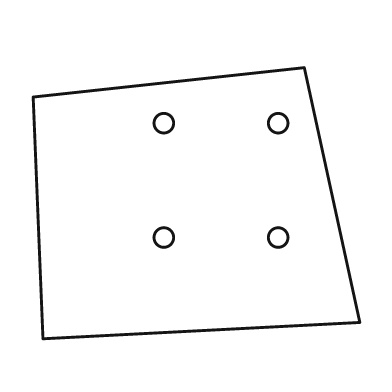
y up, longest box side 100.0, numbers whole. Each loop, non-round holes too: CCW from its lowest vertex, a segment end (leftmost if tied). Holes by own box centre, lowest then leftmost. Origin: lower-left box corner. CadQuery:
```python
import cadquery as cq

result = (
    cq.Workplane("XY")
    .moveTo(3.0, 0.0)
    .lineTo(100.0, 5.0)
    .lineTo(83.0, 83.0)
    .lineTo(0.0, 74.0)
    .close()
    .moveTo(40.0, 31.0)
    .circle(3.0)
    .moveTo(75.0, 31.0)
    .circle(3.0)
    .moveTo(40.0, 66.0)
    .circle(3.0)
    .moveTo(75.0, 66.0)
    .circle(3.0)
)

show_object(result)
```